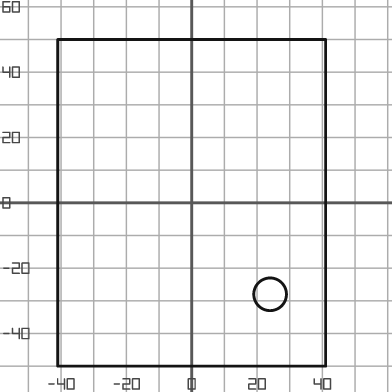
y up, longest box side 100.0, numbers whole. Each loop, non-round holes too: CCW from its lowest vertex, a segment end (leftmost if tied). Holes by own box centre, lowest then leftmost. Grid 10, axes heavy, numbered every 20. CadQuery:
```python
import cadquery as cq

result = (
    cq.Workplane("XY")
    .moveTo(-41.0, -50.0)
    .lineTo(41.0, -50.0)
    .lineTo(41.0, 50.0)
    .lineTo(-41.0, 50.0)
    .close()
    .moveTo(24.0, -28.0)
    .circle(5.0)
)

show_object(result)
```